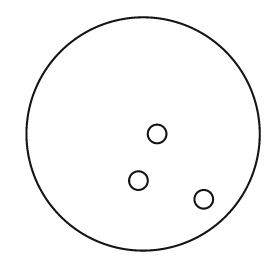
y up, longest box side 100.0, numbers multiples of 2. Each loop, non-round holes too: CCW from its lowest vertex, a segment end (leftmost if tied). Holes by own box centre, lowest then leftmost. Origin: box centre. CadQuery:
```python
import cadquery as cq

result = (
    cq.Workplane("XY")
    .moveTo(0.0, 0.0)
    .circle(50.0)
    .moveTo(26.0, -28.0)
    .circle(4.0)
    .moveTo(-2.0, -20.0)
    .circle(4.0)
    .moveTo(6.0, 0.0)
    .circle(4.0)
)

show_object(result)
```